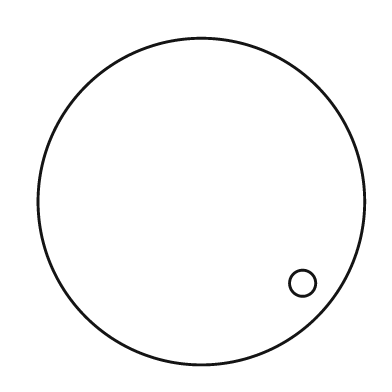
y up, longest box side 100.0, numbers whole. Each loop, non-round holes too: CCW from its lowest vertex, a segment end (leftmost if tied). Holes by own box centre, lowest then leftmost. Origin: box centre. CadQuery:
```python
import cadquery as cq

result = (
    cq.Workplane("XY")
    .moveTo(0.0, 0.0)
    .circle(50.0)
    .moveTo(31.0, -25.0)
    .circle(4.0)
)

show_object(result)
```